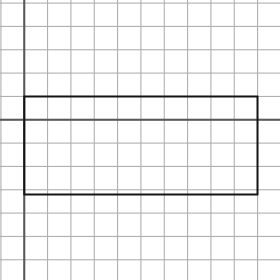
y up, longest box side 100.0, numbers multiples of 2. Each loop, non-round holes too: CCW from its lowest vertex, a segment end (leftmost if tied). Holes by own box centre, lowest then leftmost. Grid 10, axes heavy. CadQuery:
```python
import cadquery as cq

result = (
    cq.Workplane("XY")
    .moveTo(0.0, -32.0)
    .lineTo(100.0, -32.0)
    .lineTo(100.0, 10.0)
    .lineTo(0.0, 10.0)
    .close()
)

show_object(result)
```